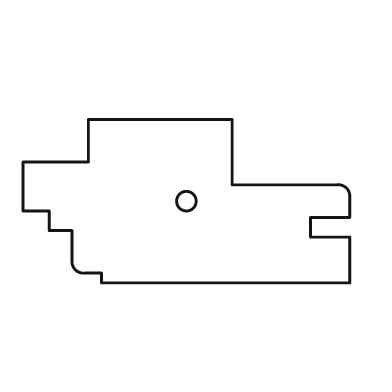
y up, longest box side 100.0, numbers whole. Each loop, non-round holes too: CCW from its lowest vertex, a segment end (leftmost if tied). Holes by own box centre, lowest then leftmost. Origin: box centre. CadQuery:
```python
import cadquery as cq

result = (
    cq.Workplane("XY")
    .moveTo(-26.0, -25.0)
    .lineTo(50.0, -25.0)
    .lineTo(50.0, -11.0)
    .lineTo(38.0, -11.0)
    .lineTo(38.0, -5.0)
    .lineTo(50.0, -5.0)
    .lineTo(50.0, 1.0)
    .threePointArc((49.0, 4.0), (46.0, 5.0))
    .lineTo(14.0, 5.0)
    .lineTo(14.0, 25.0)
    .lineTo(-30.0, 25.0)
    .lineTo(-30.0, 12.0)
    .lineTo(-50.0, 12.0)
    .lineTo(-50.0, -3.0)
    .lineTo(-42.0, -3.0)
    .lineTo(-42.0, -9.0)
    .lineTo(-35.0, -9.0)
    .lineTo(-35.0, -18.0)
    .threePointArc((-34.0, -21.0), (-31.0, -22.0))
    .lineTo(-26.0, -22.0)
    .close()
    .moveTo(0.0, 0.0)
    .circle(3.0)
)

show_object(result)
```